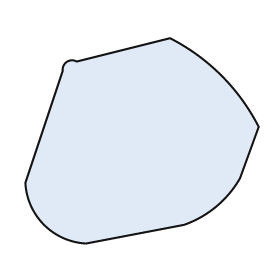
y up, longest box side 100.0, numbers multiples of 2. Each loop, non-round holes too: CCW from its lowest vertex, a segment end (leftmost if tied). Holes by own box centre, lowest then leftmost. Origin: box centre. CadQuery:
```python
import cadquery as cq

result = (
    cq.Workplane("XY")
    .moveTo(-24.0, -44.0)
    .lineTo(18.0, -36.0)
    .threePointArc((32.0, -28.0), (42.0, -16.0))
    .lineTo(50.0, 6.0)
    .threePointArc((34.0, 28.0), (12.0, 44.0))
    .lineTo(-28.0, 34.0)
    .threePointArc((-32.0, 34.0), (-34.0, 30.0))
    .lineTo(-50.0, -18.0)
    .threePointArc((-42.0, -36.0), (-24.0, -44.0))
    .close()
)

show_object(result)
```